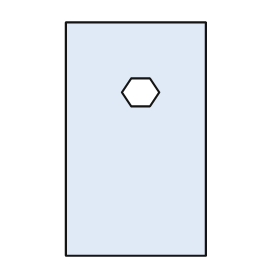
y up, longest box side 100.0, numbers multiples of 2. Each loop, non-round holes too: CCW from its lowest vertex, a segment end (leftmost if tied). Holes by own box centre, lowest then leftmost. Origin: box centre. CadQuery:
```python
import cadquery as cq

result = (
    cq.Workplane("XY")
    .moveTo(-30.0, -50.0)
    .lineTo(30.0, -50.0)
    .lineTo(30.0, 50.0)
    .lineTo(-30.0, 50.0)
    .close()
    .moveTo(-2.0, 14.0)
    .lineTo(6.0, 14.0)
    .lineTo(10.0, 20.0)
    .lineTo(6.0, 26.0)
    .lineTo(-2.0, 26.0)
    .lineTo(-6.0, 20.0)
    .close()
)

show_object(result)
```